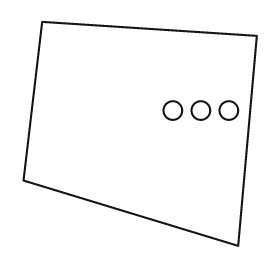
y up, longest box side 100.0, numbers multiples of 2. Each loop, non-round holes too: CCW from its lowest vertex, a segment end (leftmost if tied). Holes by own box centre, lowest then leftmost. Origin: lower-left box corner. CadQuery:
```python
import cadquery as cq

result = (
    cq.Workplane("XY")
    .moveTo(92.0, 0.0)
    .lineTo(100.0, 90.0)
    .lineTo(8.0, 96.0)
    .lineTo(0.0, 28.0)
    .close()
    .moveTo(64.0, 58.0)
    .circle(4.0)
    .moveTo(76.0, 58.0)
    .circle(4.0)
    .moveTo(88.0, 58.0)
    .circle(4.0)
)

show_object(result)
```